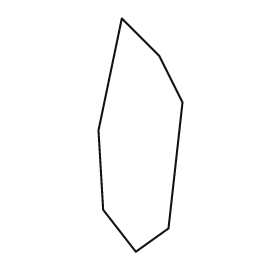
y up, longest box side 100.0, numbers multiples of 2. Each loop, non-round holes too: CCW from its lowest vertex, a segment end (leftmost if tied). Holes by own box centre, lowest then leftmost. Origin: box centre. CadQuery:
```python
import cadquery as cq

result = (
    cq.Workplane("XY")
    .moveTo(-2.0, -50.0)
    .lineTo(12.0, -40.0)
    .lineTo(18.0, 14.0)
    .lineTo(8.0, 34.0)
    .lineTo(-8.0, 50.0)
    .lineTo(-18.0, 2.0)
    .lineTo(-16.0, -32.0)
    .close()
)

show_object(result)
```